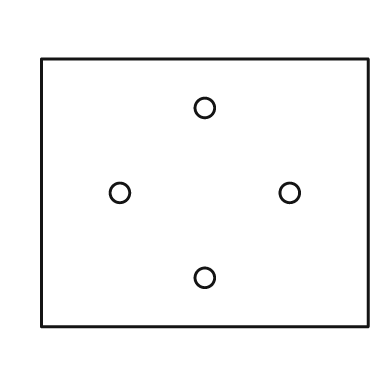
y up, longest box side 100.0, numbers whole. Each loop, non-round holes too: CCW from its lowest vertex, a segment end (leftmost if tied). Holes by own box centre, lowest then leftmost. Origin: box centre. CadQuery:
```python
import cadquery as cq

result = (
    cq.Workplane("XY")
    .moveTo(-50.0, -41.0)
    .lineTo(50.0, -41.0)
    .lineTo(50.0, 41.0)
    .lineTo(-50.0, 41.0)
    .close()
    .moveTo(0.0, -26.0)
    .circle(3.0)
    .moveTo(-26.0, 0.0)
    .circle(3.0)
    .moveTo(26.0, 0.0)
    .circle(3.0)
    .moveTo(0.0, 26.0)
    .circle(3.0)
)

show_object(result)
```